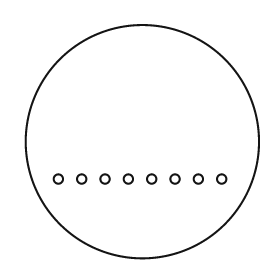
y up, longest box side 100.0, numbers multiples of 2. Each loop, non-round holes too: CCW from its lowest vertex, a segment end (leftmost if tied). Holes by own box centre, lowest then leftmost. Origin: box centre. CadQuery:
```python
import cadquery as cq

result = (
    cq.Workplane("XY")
    .moveTo(0.0, 0.0)
    .circle(50.0)
    .moveTo(-36.0, -16.0)
    .circle(2.0)
    .moveTo(-26.0, -16.0)
    .circle(2.0)
    .moveTo(-16.0, -16.0)
    .circle(2.0)
    .moveTo(-6.0, -16.0)
    .circle(2.0)
    .moveTo(4.0, -16.0)
    .circle(2.0)
    .moveTo(14.0, -16.0)
    .circle(2.0)
    .moveTo(24.0, -16.0)
    .circle(2.0)
    .moveTo(34.0, -16.0)
    .circle(2.0)
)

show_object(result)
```